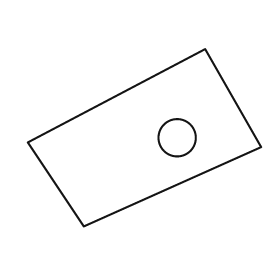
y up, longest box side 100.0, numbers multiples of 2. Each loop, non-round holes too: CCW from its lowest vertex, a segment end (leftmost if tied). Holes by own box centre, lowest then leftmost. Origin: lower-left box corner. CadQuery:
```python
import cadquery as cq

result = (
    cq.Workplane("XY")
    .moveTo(24.0, 0.0)
    .lineTo(100.0, 34.0)
    .lineTo(76.0, 76.0)
    .lineTo(0.0, 36.0)
    .close()
    .moveTo(64.0, 38.0)
    .circle(8.0)
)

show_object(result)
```